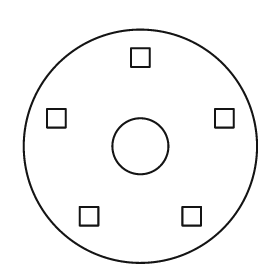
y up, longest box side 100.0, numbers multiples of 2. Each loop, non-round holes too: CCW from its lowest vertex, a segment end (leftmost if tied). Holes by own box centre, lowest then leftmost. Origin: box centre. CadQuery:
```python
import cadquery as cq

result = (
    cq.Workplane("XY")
    .moveTo(0.0, 0.0)
    .circle(50.0)
    .moveTo(-26.0, -34.0)
    .lineTo(-18.0, -34.0)
    .lineTo(-18.0, -26.0)
    .lineTo(-26.0, -26.0)
    .close()
    .moveTo(18.0, -34.0)
    .lineTo(26.0, -34.0)
    .lineTo(26.0, -26.0)
    .lineTo(18.0, -26.0)
    .close()
    .moveTo(0.0, 0.0)
    .circle(12.0)
    .moveTo(-40.0, 8.0)
    .lineTo(-32.0, 8.0)
    .lineTo(-32.0, 16.0)
    .lineTo(-40.0, 16.0)
    .close()
    .moveTo(32.0, 8.0)
    .lineTo(40.0, 8.0)
    .lineTo(40.0, 16.0)
    .lineTo(32.0, 16.0)
    .close()
    .moveTo(-4.0, 34.0)
    .lineTo(4.0, 34.0)
    .lineTo(4.0, 42.0)
    .lineTo(-4.0, 42.0)
    .close()
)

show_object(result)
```